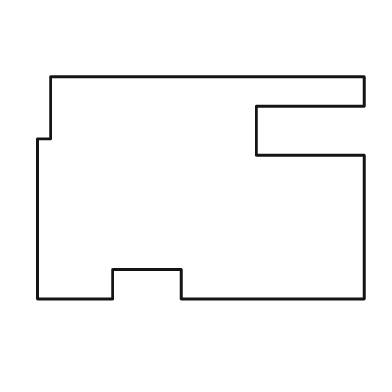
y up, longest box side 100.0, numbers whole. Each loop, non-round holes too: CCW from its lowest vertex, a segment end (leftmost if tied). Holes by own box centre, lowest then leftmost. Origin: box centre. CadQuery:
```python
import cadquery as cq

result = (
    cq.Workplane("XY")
    .moveTo(-50.0, -34.0)
    .lineTo(-27.0, -34.0)
    .lineTo(-27.0, -25.0)
    .lineTo(-6.0, -25.0)
    .lineTo(-6.0, -34.0)
    .lineTo(50.0, -34.0)
    .lineTo(50.0, 10.0)
    .lineTo(17.0, 10.0)
    .lineTo(17.0, 25.0)
    .lineTo(50.0, 25.0)
    .lineTo(50.0, 34.0)
    .lineTo(-46.0, 34.0)
    .lineTo(-46.0, 15.0)
    .lineTo(-50.0, 15.0)
    .close()
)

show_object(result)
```